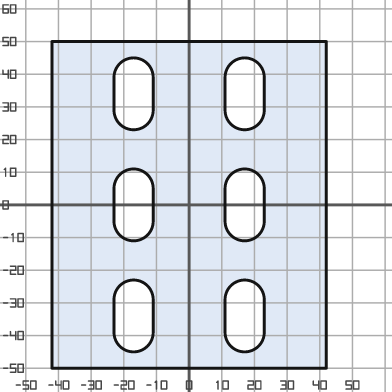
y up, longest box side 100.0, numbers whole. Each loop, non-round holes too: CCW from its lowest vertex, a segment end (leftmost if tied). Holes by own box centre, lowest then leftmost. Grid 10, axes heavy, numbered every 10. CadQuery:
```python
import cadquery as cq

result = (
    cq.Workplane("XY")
    .moveTo(-42.0, -50.0)
    .lineTo(42.0, -50.0)
    .lineTo(42.0, 50.0)
    .lineTo(-42.0, 50.0)
    .close()
    .moveTo(-23.0, -39.0)
    .threePointArc((-17.0, -45.0), (-11.0, -39.0))
    .lineTo(-11.0, -29.0)
    .threePointArc((-17.0, -23.0), (-23.0, -29.0))
    .close()
    .moveTo(11.0, -39.0)
    .threePointArc((17.0, -45.0), (23.0, -39.0))
    .lineTo(23.0, -29.0)
    .threePointArc((17.0, -23.0), (11.0, -29.0))
    .close()
    .moveTo(-23.0, -5.0)
    .threePointArc((-17.0, -11.0), (-11.0, -5.0))
    .lineTo(-11.0, 5.0)
    .threePointArc((-17.0, 11.0), (-23.0, 5.0))
    .close()
    .moveTo(11.0, -5.0)
    .threePointArc((17.0, -11.0), (23.0, -5.0))
    .lineTo(23.0, 5.0)
    .threePointArc((17.0, 11.0), (11.0, 5.0))
    .close()
    .moveTo(-23.0, 29.0)
    .threePointArc((-17.0, 23.0), (-11.0, 29.0))
    .lineTo(-11.0, 39.0)
    .threePointArc((-17.0, 45.0), (-23.0, 39.0))
    .close()
    .moveTo(11.0, 29.0)
    .threePointArc((17.0, 23.0), (23.0, 29.0))
    .lineTo(23.0, 39.0)
    .threePointArc((17.0, 45.0), (11.0, 39.0))
    .close()
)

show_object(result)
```